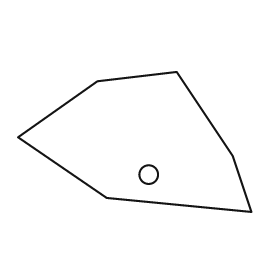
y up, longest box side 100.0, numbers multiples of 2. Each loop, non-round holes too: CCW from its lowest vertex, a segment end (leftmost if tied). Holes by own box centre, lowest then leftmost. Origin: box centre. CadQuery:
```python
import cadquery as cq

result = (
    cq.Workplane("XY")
    .moveTo(50.0, -30.0)
    .lineTo(42.0, -6.0)
    .lineTo(18.0, 30.0)
    .lineTo(-16.0, 26.0)
    .lineTo(-50.0, 2.0)
    .lineTo(-12.0, -24.0)
    .close()
    .moveTo(6.0, -14.0)
    .circle(4.0)
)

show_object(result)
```